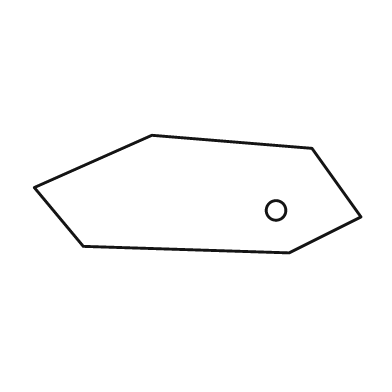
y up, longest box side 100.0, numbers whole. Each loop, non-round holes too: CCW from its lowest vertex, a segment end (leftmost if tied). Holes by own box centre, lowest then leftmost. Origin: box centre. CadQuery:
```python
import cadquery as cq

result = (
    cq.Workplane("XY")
    .moveTo(28.0, -18.0)
    .lineTo(50.0, -7.0)
    .lineTo(35.0, 14.0)
    .lineTo(-14.0, 18.0)
    .lineTo(-50.0, 2.0)
    .lineTo(-35.0, -16.0)
    .close()
    .moveTo(24.0, -5.0)
    .circle(3.0)
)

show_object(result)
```